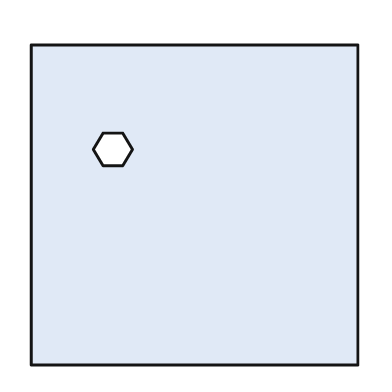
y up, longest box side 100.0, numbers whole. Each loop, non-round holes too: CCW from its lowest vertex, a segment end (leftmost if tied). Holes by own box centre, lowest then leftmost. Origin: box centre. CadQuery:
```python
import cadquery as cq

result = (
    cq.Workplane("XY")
    .moveTo(-50.0, -49.0)
    .lineTo(50.0, -49.0)
    .lineTo(50.0, 49.0)
    .lineTo(-50.0, 49.0)
    .close()
    .moveTo(-28.0, 12.0)
    .lineTo(-22.0, 12.0)
    .lineTo(-19.0, 17.0)
    .lineTo(-22.0, 22.0)
    .lineTo(-28.0, 22.0)
    .lineTo(-31.0, 17.0)
    .close()
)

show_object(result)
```